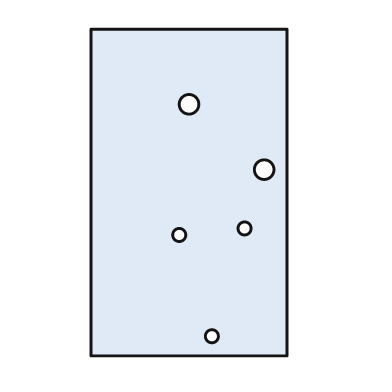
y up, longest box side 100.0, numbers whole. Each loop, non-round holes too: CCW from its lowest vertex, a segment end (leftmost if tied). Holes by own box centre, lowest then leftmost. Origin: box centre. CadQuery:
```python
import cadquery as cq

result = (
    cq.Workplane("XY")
    .moveTo(-30.0, -50.0)
    .lineTo(30.0, -50.0)
    .lineTo(30.0, 50.0)
    .lineTo(-30.0, 50.0)
    .close()
    .moveTo(7.0, -44.0)
    .circle(2.0)
    .moveTo(-3.0, -13.0)
    .circle(2.0)
    .moveTo(17.0, -11.0)
    .circle(2.0)
    .moveTo(23.0, 7.0)
    .circle(3.0)
    .moveTo(0.0, 27.0)
    .circle(3.0)
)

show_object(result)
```